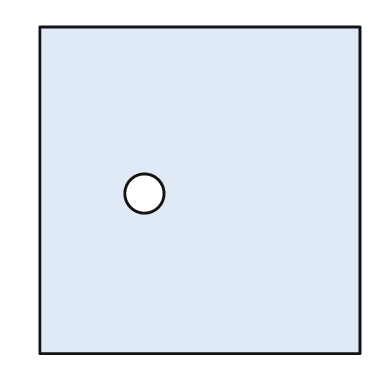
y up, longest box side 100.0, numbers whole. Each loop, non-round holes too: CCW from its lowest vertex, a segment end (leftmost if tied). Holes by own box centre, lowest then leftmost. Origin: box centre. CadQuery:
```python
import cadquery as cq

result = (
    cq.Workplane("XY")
    .moveTo(-49.0, -50.0)
    .lineTo(49.0, -50.0)
    .lineTo(49.0, 50.0)
    .lineTo(-49.0, 50.0)
    .close()
    .moveTo(-17.0, -1.0)
    .circle(6.0)
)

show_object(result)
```